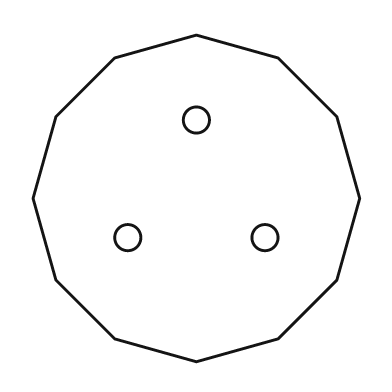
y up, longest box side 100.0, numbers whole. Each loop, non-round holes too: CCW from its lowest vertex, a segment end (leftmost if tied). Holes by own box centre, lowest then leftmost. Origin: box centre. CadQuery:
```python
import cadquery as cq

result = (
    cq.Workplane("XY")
    .moveTo(0.0, -50.0)
    .lineTo(25.0, -43.0)
    .lineTo(43.0, -25.0)
    .lineTo(50.0, 0.0)
    .lineTo(43.0, 25.0)
    .lineTo(25.0, 43.0)
    .lineTo(0.0, 50.0)
    .lineTo(-25.0, 43.0)
    .lineTo(-43.0, 25.0)
    .lineTo(-50.0, 0.0)
    .lineTo(-43.0, -25.0)
    .lineTo(-25.0, -43.0)
    .close()
    .moveTo(-21.0, -12.0)
    .circle(4.0)
    .moveTo(21.0, -12.0)
    .circle(4.0)
    .moveTo(0.0, 24.0)
    .circle(4.0)
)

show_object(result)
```